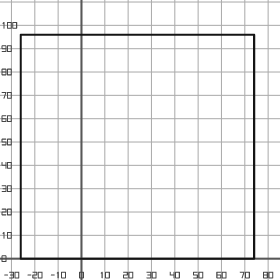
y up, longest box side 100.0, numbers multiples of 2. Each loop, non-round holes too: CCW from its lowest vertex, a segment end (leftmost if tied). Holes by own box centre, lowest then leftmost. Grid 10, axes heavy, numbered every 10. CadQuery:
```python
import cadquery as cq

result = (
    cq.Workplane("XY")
    .moveTo(-26.0, 0.0)
    .lineTo(74.0, 0.0)
    .lineTo(74.0, 96.0)
    .lineTo(-26.0, 96.0)
    .close()
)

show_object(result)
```